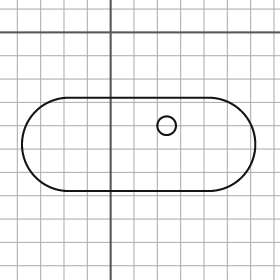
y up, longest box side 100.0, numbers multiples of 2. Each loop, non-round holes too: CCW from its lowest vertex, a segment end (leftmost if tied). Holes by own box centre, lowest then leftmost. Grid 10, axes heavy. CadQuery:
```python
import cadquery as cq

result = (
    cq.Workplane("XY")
    .moveTo(-18.0, -68.0)
    .lineTo(42.0, -68.0)
    .threePointArc((62.0, -48.0), (42.0, -28.0))
    .lineTo(-18.0, -28.0)
    .threePointArc((-38.0, -48.0), (-18.0, -68.0))
    .close()
    .moveTo(24.0, -40.0)
    .circle(4.0)
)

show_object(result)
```